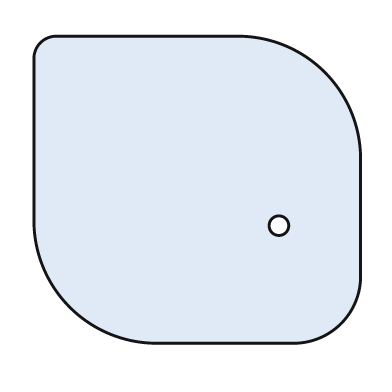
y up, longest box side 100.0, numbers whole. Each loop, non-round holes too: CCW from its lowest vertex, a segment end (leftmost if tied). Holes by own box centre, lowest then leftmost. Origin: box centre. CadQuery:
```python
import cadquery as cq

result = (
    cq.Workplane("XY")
    .moveTo(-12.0, -47.0)
    .lineTo(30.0, -47.0)
    .threePointArc((44.0, -41.0), (50.0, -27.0))
    .lineTo(50.0, 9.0)
    .threePointArc((39.0, 36.0), (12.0, 47.0))
    .lineTo(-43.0, 47.0)
    .threePointArc((-48.0, 45.0), (-50.0, 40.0))
    .lineTo(-50.0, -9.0)
    .threePointArc((-39.0, -36.0), (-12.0, -47.0))
    .close()
    .moveTo(25.0, -11.0)
    .circle(3.0)
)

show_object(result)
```